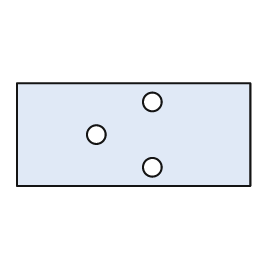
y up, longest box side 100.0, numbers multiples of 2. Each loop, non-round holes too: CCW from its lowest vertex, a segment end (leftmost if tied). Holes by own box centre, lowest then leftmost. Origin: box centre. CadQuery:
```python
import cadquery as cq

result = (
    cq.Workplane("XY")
    .moveTo(-50.0, -22.0)
    .lineTo(50.0, -22.0)
    .lineTo(50.0, 22.0)
    .lineTo(-50.0, 22.0)
    .close()
    .moveTo(8.0, -14.0)
    .circle(4.0)
    .moveTo(-16.0, 0.0)
    .circle(4.0)
    .moveTo(8.0, 14.0)
    .circle(4.0)
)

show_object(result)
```